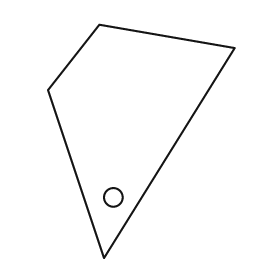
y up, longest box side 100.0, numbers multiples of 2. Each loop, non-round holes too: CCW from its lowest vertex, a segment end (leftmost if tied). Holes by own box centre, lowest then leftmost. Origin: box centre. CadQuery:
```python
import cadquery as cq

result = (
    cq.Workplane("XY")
    .moveTo(-16.0, -50.0)
    .lineTo(40.0, 40.0)
    .lineTo(-18.0, 50.0)
    .lineTo(-40.0, 22.0)
    .close()
    .moveTo(-12.0, -24.0)
    .circle(4.0)
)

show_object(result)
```